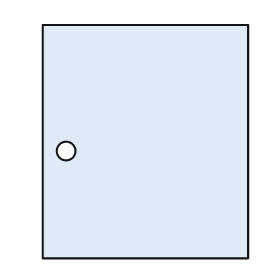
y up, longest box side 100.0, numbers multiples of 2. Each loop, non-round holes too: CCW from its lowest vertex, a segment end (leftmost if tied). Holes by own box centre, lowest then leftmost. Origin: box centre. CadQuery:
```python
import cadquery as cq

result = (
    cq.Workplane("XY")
    .moveTo(-44.0, -50.0)
    .lineTo(44.0, -50.0)
    .lineTo(44.0, 50.0)
    .lineTo(-44.0, 50.0)
    .close()
    .moveTo(-34.0, -4.0)
    .circle(4.0)
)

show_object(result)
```